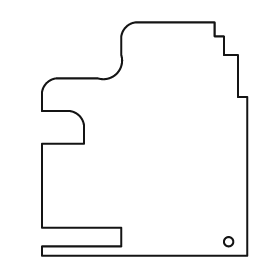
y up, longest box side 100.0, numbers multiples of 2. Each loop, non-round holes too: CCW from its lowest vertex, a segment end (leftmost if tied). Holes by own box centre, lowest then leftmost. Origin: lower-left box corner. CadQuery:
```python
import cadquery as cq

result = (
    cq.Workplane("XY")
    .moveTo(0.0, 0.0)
    .lineTo(88.0, 0.0)
    .lineTo(88.0, 68.0)
    .lineTo(84.0, 68.0)
    .lineTo(84.0, 86.0)
    .lineTo(78.0, 86.0)
    .lineTo(78.0, 94.0)
    .lineTo(74.0, 94.0)
    .lineTo(74.0, 100.0)
    .lineTo(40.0, 100.0)
    .threePointArc((36.0, 98.0), (34.0, 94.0))
    .lineTo(34.0, 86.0)
    .threePointArc((32.0, 78.0), (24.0, 76.0))
    .lineTo(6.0, 76.0)
    .threePointArc((2.0, 74.0), (0.0, 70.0))
    .lineTo(0.0, 62.0)
    .lineTo(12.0, 62.0)
    .threePointArc((16.0, 60.0), (18.0, 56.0))
    .lineTo(18.0, 48.0)
    .lineTo(0.0, 48.0)
    .lineTo(0.0, 12.0)
    .lineTo(34.0, 12.0)
    .lineTo(34.0, 4.0)
    .lineTo(0.0, 4.0)
    .close()
    .moveTo(80.0, 6.0)
    .circle(2.0)
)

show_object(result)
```